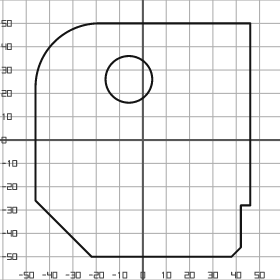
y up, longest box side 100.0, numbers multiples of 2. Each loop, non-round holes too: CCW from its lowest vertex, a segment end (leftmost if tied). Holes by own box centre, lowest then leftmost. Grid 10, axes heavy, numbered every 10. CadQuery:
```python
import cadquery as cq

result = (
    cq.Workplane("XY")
    .moveTo(-22.0, -50.0)
    .lineTo(38.0, -50.0)
    .lineTo(42.0, -46.0)
    .lineTo(42.0, -28.0)
    .lineTo(46.0, -28.0)
    .lineTo(46.0, 50.0)
    .lineTo(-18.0, 50.0)
    .threePointArc((-38.0, 42.0), (-46.0, 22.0))
    .lineTo(-46.0, -26.0)
    .close()
    .moveTo(-6.0, 26.0)
    .circle(10.0)
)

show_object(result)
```